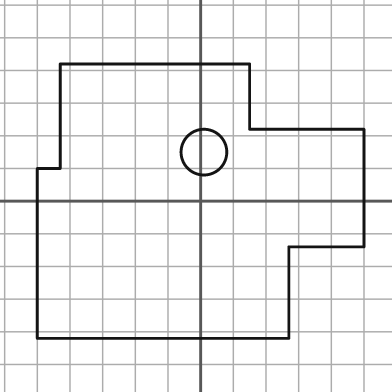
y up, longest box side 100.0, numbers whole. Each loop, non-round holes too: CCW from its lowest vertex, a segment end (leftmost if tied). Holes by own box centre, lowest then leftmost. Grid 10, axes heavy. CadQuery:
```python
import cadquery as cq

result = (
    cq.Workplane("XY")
    .moveTo(-50.0, -42.0)
    .lineTo(27.0, -42.0)
    .lineTo(27.0, -14.0)
    .lineTo(50.0, -14.0)
    .lineTo(50.0, 22.0)
    .lineTo(15.0, 22.0)
    .lineTo(15.0, 42.0)
    .lineTo(-43.0, 42.0)
    .lineTo(-43.0, 10.0)
    .lineTo(-50.0, 10.0)
    .close()
    .moveTo(1.0, 15.0)
    .circle(7.0)
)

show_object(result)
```